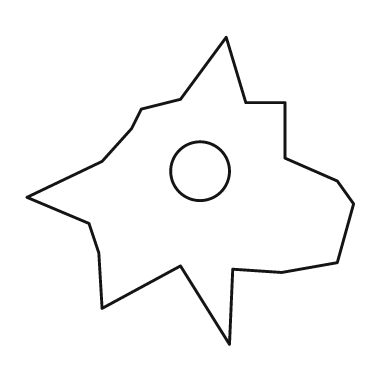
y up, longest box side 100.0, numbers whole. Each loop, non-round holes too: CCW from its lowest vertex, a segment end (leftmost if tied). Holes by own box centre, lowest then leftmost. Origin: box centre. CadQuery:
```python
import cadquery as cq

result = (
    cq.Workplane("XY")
    .moveTo(12.0, -47.0)
    .lineTo(13.0, -24.0)
    .lineTo(28.0, -25.0)
    .lineTo(45.0, -22.0)
    .lineTo(50.0, -4.0)
    .lineTo(45.0, 3.0)
    .lineTo(29.0, 10.0)
    .lineTo(29.0, 27.0)
    .lineTo(17.0, 27.0)
    .lineTo(11.0, 47.0)
    .lineTo(-3.0, 28.0)
    .lineTo(-15.0, 25.0)
    .lineTo(-18.0, 19.0)
    .lineTo(-27.0, 9.0)
    .lineTo(-50.0, -2.0)
    .lineTo(-31.0, -10.0)
    .lineTo(-28.0, -19.0)
    .lineTo(-27.0, -36.0)
    .lineTo(-3.0, -23.0)
    .close()
    .moveTo(3.0, 6.0)
    .circle(9.0)
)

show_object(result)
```